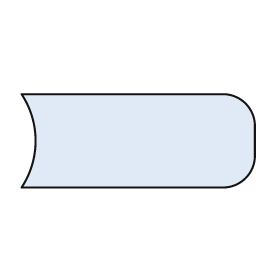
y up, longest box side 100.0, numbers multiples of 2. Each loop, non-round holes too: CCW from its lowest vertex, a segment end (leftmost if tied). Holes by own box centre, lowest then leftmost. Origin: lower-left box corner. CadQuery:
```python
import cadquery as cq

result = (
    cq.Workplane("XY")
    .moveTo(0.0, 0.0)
    .lineTo(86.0, 0.0)
    .threePointArc((96.0, 4.0), (100.0, 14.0))
    .lineTo(100.0, 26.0)
    .threePointArc((96.0, 36.0), (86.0, 40.0))
    .lineTo(0.0, 40.0)
    .threePointArc((6.0, 20.0), (0.0, 0.0))
    .close()
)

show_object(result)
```